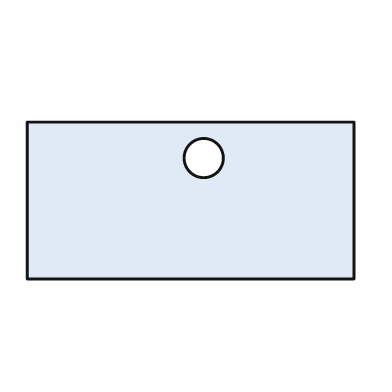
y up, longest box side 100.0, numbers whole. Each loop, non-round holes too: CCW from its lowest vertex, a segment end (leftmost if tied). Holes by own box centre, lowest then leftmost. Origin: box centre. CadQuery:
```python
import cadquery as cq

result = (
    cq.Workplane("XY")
    .moveTo(-50.0, -24.0)
    .lineTo(50.0, -24.0)
    .lineTo(50.0, 24.0)
    .lineTo(-50.0, 24.0)
    .close()
    .moveTo(4.0, 13.0)
    .circle(6.0)
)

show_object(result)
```